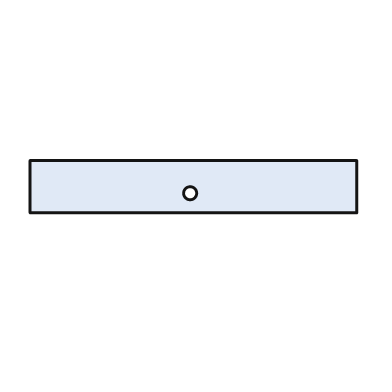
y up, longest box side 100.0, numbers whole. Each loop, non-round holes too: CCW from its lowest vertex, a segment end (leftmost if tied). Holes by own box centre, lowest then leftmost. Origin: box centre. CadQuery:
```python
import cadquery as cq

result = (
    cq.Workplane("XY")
    .moveTo(-50.0, -8.0)
    .lineTo(50.0, -8.0)
    .lineTo(50.0, 8.0)
    .lineTo(-50.0, 8.0)
    .close()
    .moveTo(-1.0, -2.0)
    .circle(2.0)
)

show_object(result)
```